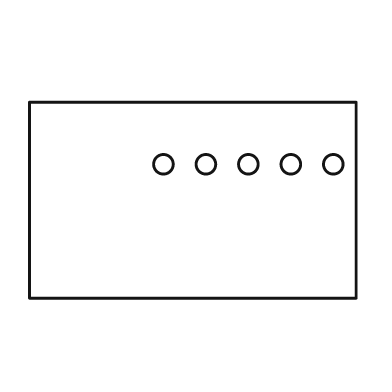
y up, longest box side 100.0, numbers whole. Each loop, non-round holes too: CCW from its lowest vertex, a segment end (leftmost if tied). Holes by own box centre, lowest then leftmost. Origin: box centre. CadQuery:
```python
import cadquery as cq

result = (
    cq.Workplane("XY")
    .moveTo(-50.0, -30.0)
    .lineTo(50.0, -30.0)
    .lineTo(50.0, 30.0)
    .lineTo(-50.0, 30.0)
    .close()
    .moveTo(-9.0, 11.0)
    .circle(3.0)
    .moveTo(4.0, 11.0)
    .circle(3.0)
    .moveTo(17.0, 11.0)
    .circle(3.0)
    .moveTo(30.0, 11.0)
    .circle(3.0)
    .moveTo(43.0, 11.0)
    .circle(3.0)
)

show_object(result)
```